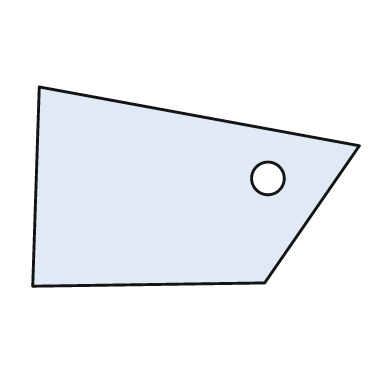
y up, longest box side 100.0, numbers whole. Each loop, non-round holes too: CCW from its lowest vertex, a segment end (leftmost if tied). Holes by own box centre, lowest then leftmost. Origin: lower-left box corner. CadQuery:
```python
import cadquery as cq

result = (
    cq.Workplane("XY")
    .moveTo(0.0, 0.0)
    .lineTo(71.0, 1.0)
    .lineTo(100.0, 43.0)
    .lineTo(2.0, 61.0)
    .close()
    .moveTo(72.0, 33.0)
    .circle(5.0)
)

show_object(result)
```